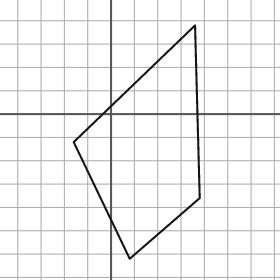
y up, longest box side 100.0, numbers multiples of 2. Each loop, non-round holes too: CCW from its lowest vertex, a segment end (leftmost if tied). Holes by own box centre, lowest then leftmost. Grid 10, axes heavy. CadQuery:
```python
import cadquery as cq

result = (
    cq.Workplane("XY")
    .moveTo(8.0, -62.0)
    .lineTo(38.0, -36.0)
    .lineTo(36.0, 38.0)
    .lineTo(-16.0, -12.0)
    .close()
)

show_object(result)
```